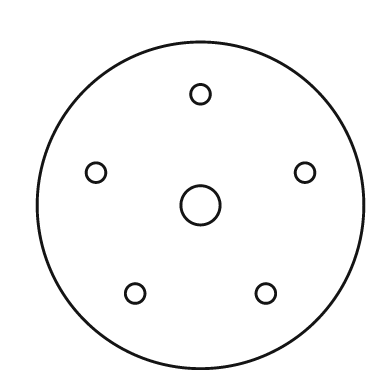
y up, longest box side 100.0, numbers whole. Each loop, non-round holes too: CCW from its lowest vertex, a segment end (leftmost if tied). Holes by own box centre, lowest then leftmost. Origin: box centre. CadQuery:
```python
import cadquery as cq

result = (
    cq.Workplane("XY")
    .moveTo(0.0, 0.0)
    .circle(50.0)
    .moveTo(-20.0, -27.0)
    .circle(3.0)
    .moveTo(20.0, -27.0)
    .circle(3.0)
    .moveTo(0.0, 0.0)
    .circle(6.0)
    .moveTo(-32.0, 10.0)
    .circle(3.0)
    .moveTo(32.0, 10.0)
    .circle(3.0)
    .moveTo(0.0, 34.0)
    .circle(3.0)
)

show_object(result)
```